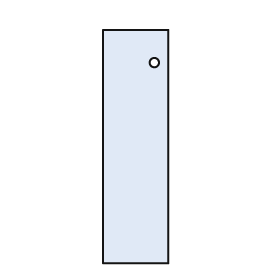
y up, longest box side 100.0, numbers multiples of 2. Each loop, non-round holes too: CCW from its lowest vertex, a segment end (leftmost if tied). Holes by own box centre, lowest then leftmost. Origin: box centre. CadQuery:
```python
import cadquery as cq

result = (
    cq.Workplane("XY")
    .moveTo(-14.0, -50.0)
    .lineTo(14.0, -50.0)
    .lineTo(14.0, 50.0)
    .lineTo(-14.0, 50.0)
    .close()
    .moveTo(8.0, 36.0)
    .circle(2.0)
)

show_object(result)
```